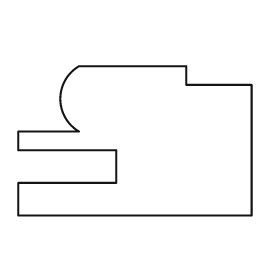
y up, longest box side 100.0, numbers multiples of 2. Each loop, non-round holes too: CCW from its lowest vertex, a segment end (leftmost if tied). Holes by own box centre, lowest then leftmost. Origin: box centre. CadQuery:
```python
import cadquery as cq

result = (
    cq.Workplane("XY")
    .moveTo(-50.0, -32.0)
    .lineTo(50.0, -32.0)
    .lineTo(50.0, 24.0)
    .lineTo(22.0, 24.0)
    .lineTo(22.0, 32.0)
    .lineTo(-24.0, 32.0)
    .threePointArc((-32.0, 18.0), (-24.0, 4.0))
    .lineTo(-50.0, 4.0)
    .lineTo(-50.0, -4.0)
    .lineTo(-8.0, -4.0)
    .lineTo(-8.0, -18.0)
    .lineTo(-50.0, -18.0)
    .close()
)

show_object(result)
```